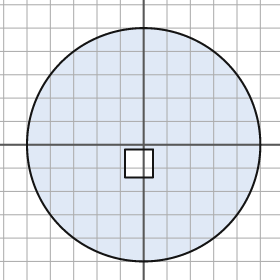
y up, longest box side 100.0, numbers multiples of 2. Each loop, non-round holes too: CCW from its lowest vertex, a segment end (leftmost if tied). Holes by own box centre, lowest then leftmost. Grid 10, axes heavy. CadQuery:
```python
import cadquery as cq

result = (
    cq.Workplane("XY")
    .moveTo(0.0, 0.0)
    .circle(50.0)
    .moveTo(-8.0, -14.0)
    .lineTo(4.0, -14.0)
    .lineTo(4.0, -2.0)
    .lineTo(-8.0, -2.0)
    .close()
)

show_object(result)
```